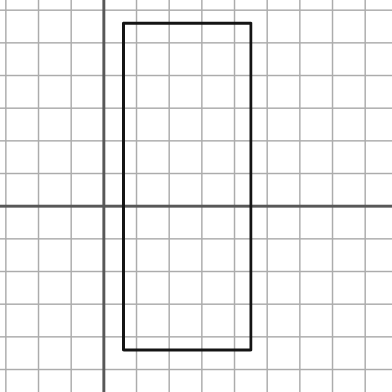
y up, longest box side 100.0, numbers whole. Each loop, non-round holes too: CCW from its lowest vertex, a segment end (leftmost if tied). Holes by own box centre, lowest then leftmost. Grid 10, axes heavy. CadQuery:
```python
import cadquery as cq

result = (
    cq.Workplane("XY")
    .moveTo(6.0, -44.0)
    .lineTo(45.0, -44.0)
    .lineTo(45.0, 56.0)
    .lineTo(6.0, 56.0)
    .close()
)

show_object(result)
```